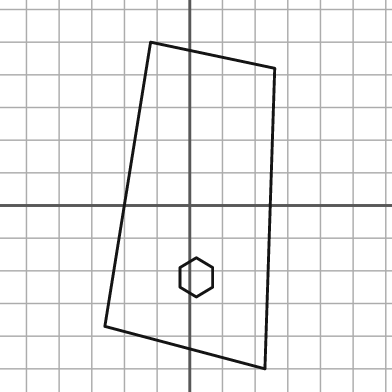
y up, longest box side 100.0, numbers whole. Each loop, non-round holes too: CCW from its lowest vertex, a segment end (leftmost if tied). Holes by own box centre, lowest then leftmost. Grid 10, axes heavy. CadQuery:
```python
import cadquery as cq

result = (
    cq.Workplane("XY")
    .moveTo(23.0, -50.0)
    .lineTo(26.0, 42.0)
    .lineTo(-12.0, 50.0)
    .lineTo(-26.0, -37.0)
    .close()
    .moveTo(2.0, -28.0)
    .lineTo(7.0, -25.0)
    .lineTo(7.0, -19.0)
    .lineTo(2.0, -16.0)
    .lineTo(-3.0, -19.0)
    .lineTo(-3.0, -25.0)
    .close()
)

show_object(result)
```